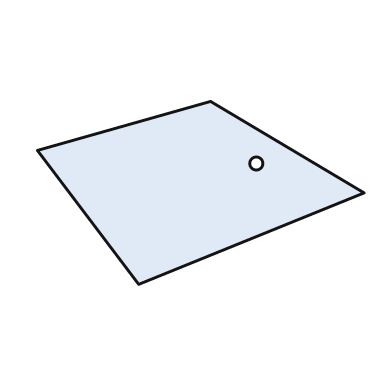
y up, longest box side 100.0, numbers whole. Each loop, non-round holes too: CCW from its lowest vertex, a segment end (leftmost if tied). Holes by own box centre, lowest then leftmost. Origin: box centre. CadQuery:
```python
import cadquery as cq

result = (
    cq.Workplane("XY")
    .moveTo(-19.0, -28.0)
    .lineTo(50.0, 0.0)
    .lineTo(3.0, 28.0)
    .lineTo(-50.0, 13.0)
    .close()
    .moveTo(17.0, 9.0)
    .circle(2.0)
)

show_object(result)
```